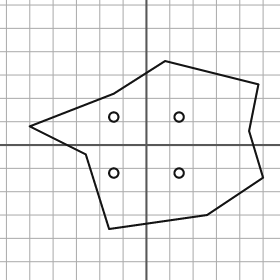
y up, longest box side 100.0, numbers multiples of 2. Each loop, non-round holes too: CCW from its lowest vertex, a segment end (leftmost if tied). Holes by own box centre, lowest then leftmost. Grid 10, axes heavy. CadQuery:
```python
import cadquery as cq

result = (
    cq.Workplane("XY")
    .moveTo(-16.0, -36.0)
    .lineTo(26.0, -30.0)
    .lineTo(50.0, -14.0)
    .lineTo(44.0, 6.0)
    .lineTo(48.0, 26.0)
    .lineTo(8.0, 36.0)
    .lineTo(-14.0, 22.0)
    .lineTo(-50.0, 8.0)
    .lineTo(-26.0, -4.0)
    .close()
    .moveTo(-14.0, -12.0)
    .circle(2.0)
    .moveTo(14.0, -12.0)
    .circle(2.0)
    .moveTo(-14.0, 12.0)
    .circle(2.0)
    .moveTo(14.0, 12.0)
    .circle(2.0)
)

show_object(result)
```